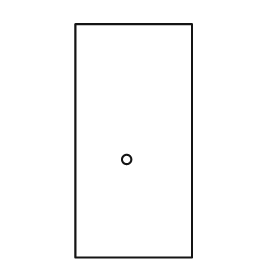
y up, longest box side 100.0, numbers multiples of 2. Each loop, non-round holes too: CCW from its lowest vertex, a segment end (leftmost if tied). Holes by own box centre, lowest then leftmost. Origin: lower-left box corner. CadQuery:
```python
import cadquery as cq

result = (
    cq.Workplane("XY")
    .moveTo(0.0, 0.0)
    .lineTo(50.0, 0.0)
    .lineTo(50.0, 100.0)
    .lineTo(0.0, 100.0)
    .close()
    .moveTo(22.0, 42.0)
    .circle(2.0)
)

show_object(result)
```